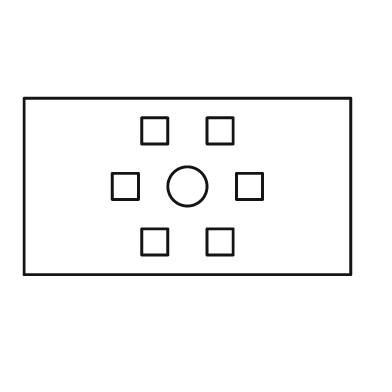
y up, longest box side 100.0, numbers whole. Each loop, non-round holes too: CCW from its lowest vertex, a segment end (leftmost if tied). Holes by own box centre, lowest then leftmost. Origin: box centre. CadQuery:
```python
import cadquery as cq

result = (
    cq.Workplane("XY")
    .moveTo(-50.0, -27.0)
    .lineTo(50.0, -27.0)
    .lineTo(50.0, 27.0)
    .lineTo(-50.0, 27.0)
    .close()
    .moveTo(-14.0, -21.0)
    .lineTo(-6.0, -21.0)
    .lineTo(-6.0, -13.0)
    .lineTo(-14.0, -13.0)
    .close()
    .moveTo(6.0, -21.0)
    .lineTo(14.0, -21.0)
    .lineTo(14.0, -13.0)
    .lineTo(6.0, -13.0)
    .close()
    .moveTo(-23.0, -4.0)
    .lineTo(-15.0, -4.0)
    .lineTo(-15.0, 4.0)
    .lineTo(-23.0, 4.0)
    .close()
    .moveTo(0.0, 0.0)
    .circle(6.0)
    .moveTo(15.0, -4.0)
    .lineTo(23.0, -4.0)
    .lineTo(23.0, 4.0)
    .lineTo(15.0, 4.0)
    .close()
    .moveTo(-14.0, 13.0)
    .lineTo(-6.0, 13.0)
    .lineTo(-6.0, 21.0)
    .lineTo(-14.0, 21.0)
    .close()
    .moveTo(6.0, 13.0)
    .lineTo(14.0, 13.0)
    .lineTo(14.0, 21.0)
    .lineTo(6.0, 21.0)
    .close()
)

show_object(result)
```